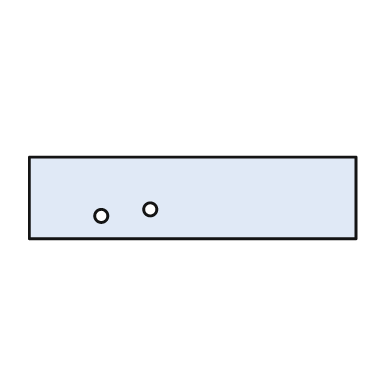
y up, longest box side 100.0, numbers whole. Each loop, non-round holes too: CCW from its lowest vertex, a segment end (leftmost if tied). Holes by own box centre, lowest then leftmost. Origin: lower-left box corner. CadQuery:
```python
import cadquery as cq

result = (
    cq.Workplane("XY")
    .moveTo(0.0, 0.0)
    .lineTo(100.0, 0.0)
    .lineTo(100.0, 25.0)
    .lineTo(0.0, 25.0)
    .close()
    .moveTo(22.0, 7.0)
    .circle(2.0)
    .moveTo(37.0, 9.0)
    .circle(2.0)
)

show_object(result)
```